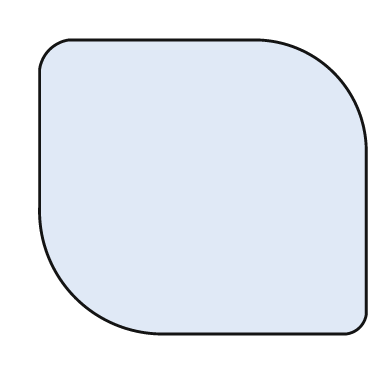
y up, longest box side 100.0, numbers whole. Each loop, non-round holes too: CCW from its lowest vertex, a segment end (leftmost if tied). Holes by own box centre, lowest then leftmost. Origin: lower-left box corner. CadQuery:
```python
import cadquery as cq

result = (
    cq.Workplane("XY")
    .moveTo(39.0, 0.0)
    .lineTo(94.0, 0.0)
    .threePointArc((98.0, 2.0), (100.0, 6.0))
    .lineTo(100.0, 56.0)
    .threePointArc((90.0, 80.0), (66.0, 90.0))
    .lineTo(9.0, 90.0)
    .threePointArc((3.0, 87.0), (0.0, 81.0))
    .lineTo(0.0, 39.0)
    .threePointArc((11.0, 11.0), (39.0, 0.0))
    .close()
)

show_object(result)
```